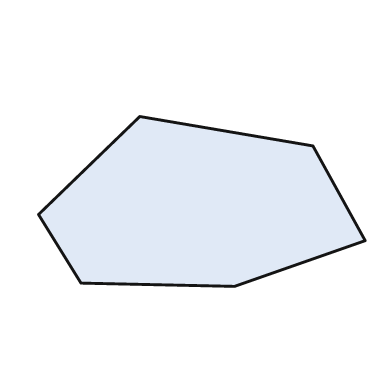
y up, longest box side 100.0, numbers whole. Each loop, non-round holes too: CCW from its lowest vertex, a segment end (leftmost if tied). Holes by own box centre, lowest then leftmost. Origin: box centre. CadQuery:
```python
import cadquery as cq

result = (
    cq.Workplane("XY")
    .moveTo(10.0, -26.0)
    .lineTo(50.0, -12.0)
    .lineTo(34.0, 17.0)
    .lineTo(-19.0, 26.0)
    .lineTo(-50.0, -4.0)
    .lineTo(-37.0, -25.0)
    .close()
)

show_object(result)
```